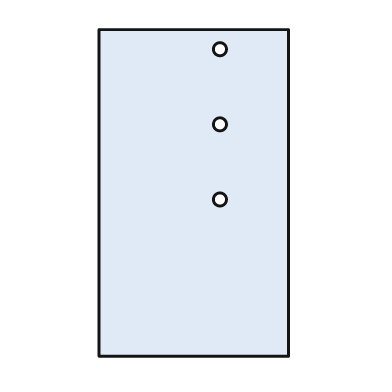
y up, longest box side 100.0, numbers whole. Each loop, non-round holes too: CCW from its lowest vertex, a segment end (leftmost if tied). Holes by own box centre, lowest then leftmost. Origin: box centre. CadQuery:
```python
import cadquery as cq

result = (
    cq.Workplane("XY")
    .moveTo(-29.0, -50.0)
    .lineTo(29.0, -50.0)
    .lineTo(29.0, 50.0)
    .lineTo(-29.0, 50.0)
    .close()
    .moveTo(8.0, -2.0)
    .circle(2.0)
    .moveTo(8.0, 21.0)
    .circle(2.0)
    .moveTo(8.0, 44.0)
    .circle(2.0)
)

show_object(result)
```